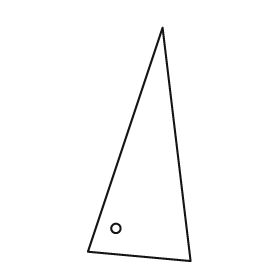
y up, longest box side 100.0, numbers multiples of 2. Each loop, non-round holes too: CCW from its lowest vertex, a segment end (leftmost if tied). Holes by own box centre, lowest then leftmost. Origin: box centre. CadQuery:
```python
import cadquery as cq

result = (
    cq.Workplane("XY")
    .moveTo(22.0, -50.0)
    .lineTo(10.0, 50.0)
    .lineTo(-22.0, -46.0)
    .close()
    .moveTo(-10.0, -36.0)
    .circle(2.0)
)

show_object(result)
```